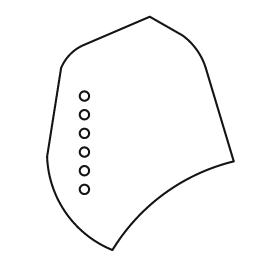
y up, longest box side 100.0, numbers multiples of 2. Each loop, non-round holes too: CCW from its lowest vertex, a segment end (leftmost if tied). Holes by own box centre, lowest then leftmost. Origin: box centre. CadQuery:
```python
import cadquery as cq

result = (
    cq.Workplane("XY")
    .moveTo(-12.0, -50.0)
    .threePointArc((10.0, -26.0), (40.0, -12.0))
    .lineTo(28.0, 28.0)
    .threePointArc((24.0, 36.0), (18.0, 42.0))
    .lineTo(4.0, 50.0)
    .lineTo(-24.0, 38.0)
    .threePointArc((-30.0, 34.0), (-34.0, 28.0))
    .lineTo(-40.0, -10.0)
    .threePointArc((-32.0, -34.0), (-12.0, -50.0))
    .close()
    .moveTo(-24.0, -24.0)
    .circle(2.0)
    .moveTo(-24.0, -16.0)
    .circle(2.0)
    .moveTo(-24.0, -8.0)
    .circle(2.0)
    .moveTo(-24.0, 0.0)
    .circle(2.0)
    .moveTo(-24.0, 8.0)
    .circle(2.0)
    .moveTo(-24.0, 16.0)
    .circle(2.0)
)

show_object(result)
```